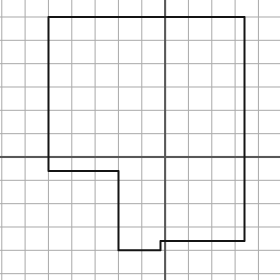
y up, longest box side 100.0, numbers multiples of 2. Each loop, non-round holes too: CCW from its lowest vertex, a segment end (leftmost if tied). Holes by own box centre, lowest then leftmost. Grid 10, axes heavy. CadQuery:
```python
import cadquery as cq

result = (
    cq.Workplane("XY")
    .moveTo(-20.0, -40.0)
    .lineTo(-2.0, -40.0)
    .lineTo(-2.0, -36.0)
    .lineTo(34.0, -36.0)
    .lineTo(34.0, 60.0)
    .lineTo(-50.0, 60.0)
    .lineTo(-50.0, -6.0)
    .lineTo(-20.0, -6.0)
    .close()
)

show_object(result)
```